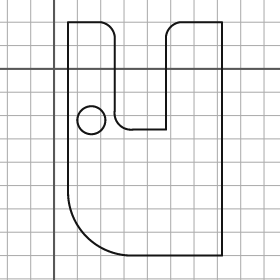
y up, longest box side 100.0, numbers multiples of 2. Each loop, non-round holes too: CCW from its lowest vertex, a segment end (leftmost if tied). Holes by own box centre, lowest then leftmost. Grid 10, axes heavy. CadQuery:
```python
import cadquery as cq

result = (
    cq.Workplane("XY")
    .moveTo(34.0, -80.0)
    .lineTo(72.0, -80.0)
    .lineTo(72.0, 20.0)
    .lineTo(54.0, 20.0)
    .threePointArc((50.0, 18.0), (48.0, 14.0))
    .lineTo(48.0, -26.0)
    .lineTo(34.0, -26.0)
    .threePointArc((28.0, -24.0), (26.0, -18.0))
    .lineTo(26.0, 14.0)
    .threePointArc((24.0, 18.0), (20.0, 20.0))
    .lineTo(6.0, 20.0)
    .lineTo(6.0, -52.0)
    .threePointArc((14.0, -72.0), (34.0, -80.0))
    .close()
    .moveTo(16.0, -22.0)
    .circle(6.0)
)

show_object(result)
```